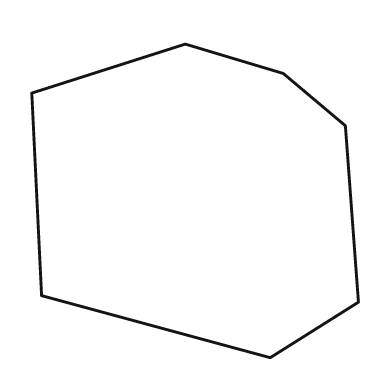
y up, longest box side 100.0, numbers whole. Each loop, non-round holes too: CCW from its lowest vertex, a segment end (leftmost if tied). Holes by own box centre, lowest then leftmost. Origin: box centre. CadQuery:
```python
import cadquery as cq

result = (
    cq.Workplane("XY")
    .moveTo(23.0, -48.0)
    .lineTo(50.0, -31.0)
    .lineTo(46.0, 23.0)
    .lineTo(27.0, 39.0)
    .lineTo(-3.0, 48.0)
    .lineTo(-50.0, 33.0)
    .lineTo(-47.0, -29.0)
    .close()
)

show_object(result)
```